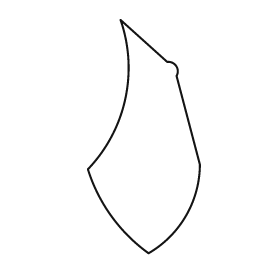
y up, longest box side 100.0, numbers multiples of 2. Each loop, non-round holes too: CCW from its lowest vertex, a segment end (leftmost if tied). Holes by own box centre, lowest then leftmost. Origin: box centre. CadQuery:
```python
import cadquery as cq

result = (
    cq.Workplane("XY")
    .moveTo(2.0, -50.0)
    .threePointArc((18.0, -34.0), (24.0, -12.0))
    .lineTo(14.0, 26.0)
    .threePointArc((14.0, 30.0), (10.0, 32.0))
    .lineTo(-10.0, 50.0)
    .threePointArc((-8.0, 16.0), (-24.0, -14.0))
    .threePointArc((-14.0, -34.0), (2.0, -50.0))
    .close()
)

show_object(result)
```